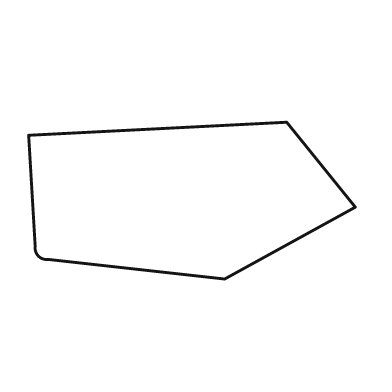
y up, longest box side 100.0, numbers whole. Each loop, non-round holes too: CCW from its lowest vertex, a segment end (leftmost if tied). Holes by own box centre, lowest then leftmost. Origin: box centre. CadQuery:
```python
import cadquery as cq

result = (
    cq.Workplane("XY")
    .moveTo(10.0, -24.0)
    .lineTo(50.0, -2.0)
    .lineTo(29.0, 24.0)
    .lineTo(-50.0, 20.0)
    .lineTo(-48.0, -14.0)
    .threePointArc((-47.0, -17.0), (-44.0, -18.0))
    .close()
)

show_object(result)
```